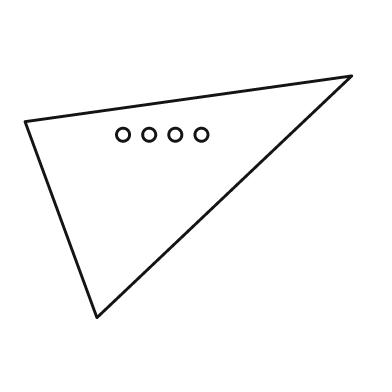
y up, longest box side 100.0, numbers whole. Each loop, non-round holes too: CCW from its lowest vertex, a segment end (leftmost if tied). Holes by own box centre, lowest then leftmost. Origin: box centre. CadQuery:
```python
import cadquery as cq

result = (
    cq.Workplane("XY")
    .moveTo(-28.0, -37.0)
    .lineTo(50.0, 37.0)
    .lineTo(-50.0, 23.0)
    .close()
    .moveTo(-20.0, 19.0)
    .circle(2.0)
    .moveTo(-12.0, 19.0)
    .circle(2.0)
    .moveTo(-4.0, 19.0)
    .circle(2.0)
    .moveTo(4.0, 19.0)
    .circle(2.0)
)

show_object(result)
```